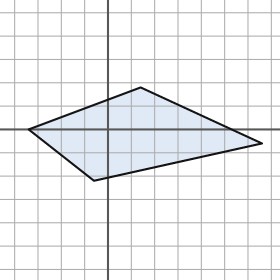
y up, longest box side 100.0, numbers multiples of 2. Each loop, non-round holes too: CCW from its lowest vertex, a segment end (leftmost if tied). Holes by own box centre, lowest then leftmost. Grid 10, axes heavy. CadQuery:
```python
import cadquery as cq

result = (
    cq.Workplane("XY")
    .moveTo(-6.0, -22.0)
    .lineTo(66.0, -6.0)
    .lineTo(14.0, 18.0)
    .lineTo(-34.0, 0.0)
    .close()
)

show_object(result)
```